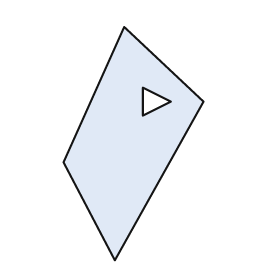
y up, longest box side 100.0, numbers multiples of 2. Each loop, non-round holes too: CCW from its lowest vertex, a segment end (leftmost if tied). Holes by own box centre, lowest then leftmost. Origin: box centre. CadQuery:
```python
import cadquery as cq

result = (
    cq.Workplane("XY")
    .moveTo(-8.0, -50.0)
    .lineTo(30.0, 18.0)
    .lineTo(-4.0, 50.0)
    .lineTo(-30.0, -8.0)
    .close()
    .moveTo(4.0, 12.0)
    .lineTo(16.0, 18.0)
    .lineTo(4.0, 24.0)
    .close()
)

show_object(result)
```